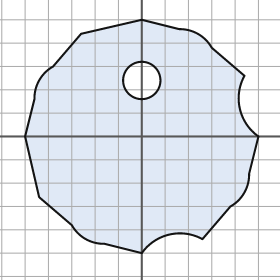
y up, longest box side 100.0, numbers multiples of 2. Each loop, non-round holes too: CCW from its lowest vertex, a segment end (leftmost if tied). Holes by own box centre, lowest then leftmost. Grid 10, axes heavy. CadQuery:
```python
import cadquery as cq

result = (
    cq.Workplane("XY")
    .moveTo(0.0, -50.0)
    .threePointArc((12.0, -42.0), (26.0, -44.0))
    .lineTo(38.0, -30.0)
    .threePointArc((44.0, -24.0), (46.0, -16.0))
    .lineTo(50.0, 0.0)
    .threePointArc((42.0, 12.0), (44.0, 26.0))
    .lineTo(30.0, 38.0)
    .threePointArc((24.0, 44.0), (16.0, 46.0))
    .lineTo(0.0, 50.0)
    .lineTo(-26.0, 44.0)
    .lineTo(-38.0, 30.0)
    .threePointArc((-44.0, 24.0), (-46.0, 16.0))
    .lineTo(-50.0, 0.0)
    .lineTo(-44.0, -26.0)
    .lineTo(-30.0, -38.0)
    .threePointArc((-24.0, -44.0), (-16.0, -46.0))
    .close()
    .moveTo(0.0, 24.0)
    .circle(8.0)
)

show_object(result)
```